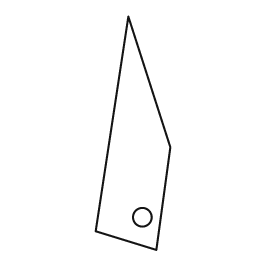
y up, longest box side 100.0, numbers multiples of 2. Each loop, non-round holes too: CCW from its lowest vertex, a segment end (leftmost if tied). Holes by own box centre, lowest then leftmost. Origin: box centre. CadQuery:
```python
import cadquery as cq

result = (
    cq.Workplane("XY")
    .moveTo(10.0, -50.0)
    .lineTo(16.0, -6.0)
    .lineTo(-2.0, 50.0)
    .lineTo(-16.0, -42.0)
    .close()
    .moveTo(4.0, -36.0)
    .circle(4.0)
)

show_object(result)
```